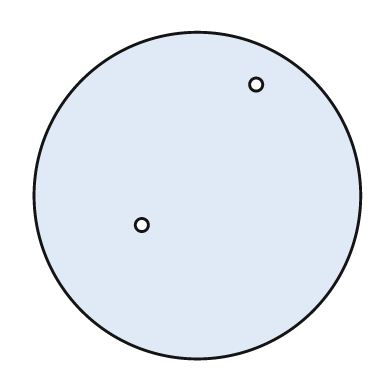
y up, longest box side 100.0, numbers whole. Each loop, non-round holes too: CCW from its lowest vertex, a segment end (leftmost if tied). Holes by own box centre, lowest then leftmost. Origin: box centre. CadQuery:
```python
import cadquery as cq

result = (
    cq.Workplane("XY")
    .moveTo(0.0, 0.0)
    .circle(50.0)
    .moveTo(-17.0, -9.0)
    .circle(2.0)
    .moveTo(18.0, 34.0)
    .circle(2.0)
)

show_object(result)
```